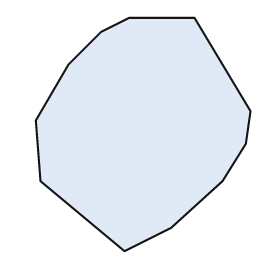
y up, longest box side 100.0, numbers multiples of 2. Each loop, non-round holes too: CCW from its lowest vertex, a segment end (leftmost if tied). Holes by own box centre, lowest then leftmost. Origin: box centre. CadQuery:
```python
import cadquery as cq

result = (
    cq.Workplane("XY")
    .moveTo(-8.0, -50.0)
    .lineTo(12.0, -40.0)
    .lineTo(34.0, -20.0)
    .lineTo(44.0, -4.0)
    .lineTo(46.0, 10.0)
    .lineTo(22.0, 50.0)
    .lineTo(-6.0, 50.0)
    .lineTo(-18.0, 44.0)
    .lineTo(-32.0, 30.0)
    .lineTo(-46.0, 6.0)
    .lineTo(-44.0, -20.0)
    .close()
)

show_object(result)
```